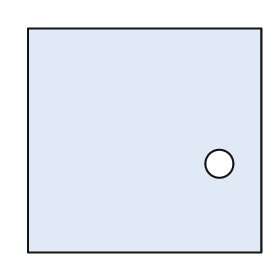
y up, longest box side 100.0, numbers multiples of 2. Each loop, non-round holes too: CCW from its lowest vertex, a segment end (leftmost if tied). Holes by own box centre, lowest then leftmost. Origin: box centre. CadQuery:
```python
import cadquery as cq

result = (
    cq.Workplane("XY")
    .moveTo(-50.0, -48.0)
    .lineTo(50.0, -48.0)
    .lineTo(50.0, 48.0)
    .lineTo(-50.0, 48.0)
    .close()
    .moveTo(32.0, -10.0)
    .circle(6.0)
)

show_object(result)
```